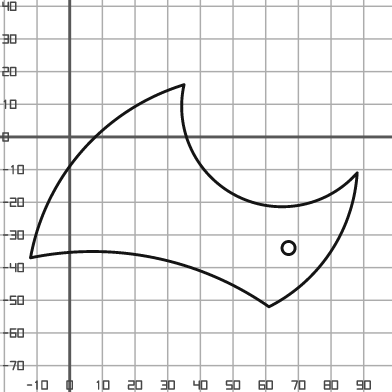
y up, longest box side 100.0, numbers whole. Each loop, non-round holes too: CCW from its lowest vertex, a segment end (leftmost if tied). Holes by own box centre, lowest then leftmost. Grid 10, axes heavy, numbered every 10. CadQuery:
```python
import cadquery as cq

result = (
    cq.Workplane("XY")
    .moveTo(61.0, -52.0)
    .threePointArc((80.0, -35.0), (88.0, -11.0))
    .threePointArc((51.0, -18.0), (35.0, 16.0))
    .threePointArc((4.0, -4.0), (-12.0, -37.0))
    .threePointArc((26.0, -37.0), (61.0, -52.0))
    .close()
    .moveTo(67.0, -34.0)
    .circle(2.0)
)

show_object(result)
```